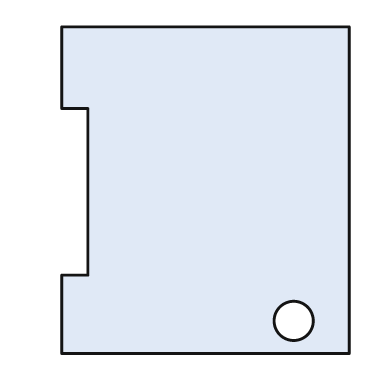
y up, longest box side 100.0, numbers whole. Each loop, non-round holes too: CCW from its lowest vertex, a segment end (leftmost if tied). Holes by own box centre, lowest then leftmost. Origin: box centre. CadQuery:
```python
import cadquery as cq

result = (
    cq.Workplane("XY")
    .moveTo(-44.0, -50.0)
    .lineTo(44.0, -50.0)
    .lineTo(44.0, 50.0)
    .lineTo(-44.0, 50.0)
    .lineTo(-44.0, 25.0)
    .lineTo(-36.0, 25.0)
    .lineTo(-36.0, -26.0)
    .lineTo(-44.0, -26.0)
    .close()
    .moveTo(27.0, -40.0)
    .circle(6.0)
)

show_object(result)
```